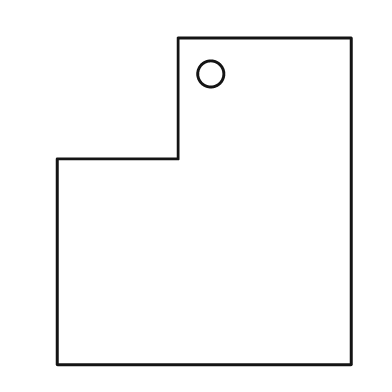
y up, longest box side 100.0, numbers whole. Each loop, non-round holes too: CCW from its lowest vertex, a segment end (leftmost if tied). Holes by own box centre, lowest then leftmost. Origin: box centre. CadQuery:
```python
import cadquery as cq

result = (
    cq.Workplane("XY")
    .moveTo(-45.0, -50.0)
    .lineTo(45.0, -50.0)
    .lineTo(45.0, 50.0)
    .lineTo(-8.0, 50.0)
    .lineTo(-8.0, 13.0)
    .lineTo(-45.0, 13.0)
    .close()
    .moveTo(2.0, 39.0)
    .circle(4.0)
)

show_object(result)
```